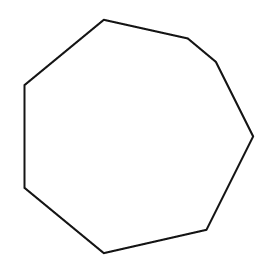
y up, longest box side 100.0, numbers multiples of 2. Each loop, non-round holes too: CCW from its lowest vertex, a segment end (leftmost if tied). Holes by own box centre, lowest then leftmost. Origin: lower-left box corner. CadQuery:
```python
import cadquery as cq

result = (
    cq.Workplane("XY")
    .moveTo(34.0, 0.0)
    .lineTo(78.0, 10.0)
    .lineTo(98.0, 50.0)
    .lineTo(82.0, 82.0)
    .lineTo(70.0, 92.0)
    .lineTo(34.0, 100.0)
    .lineTo(0.0, 72.0)
    .lineTo(0.0, 28.0)
    .close()
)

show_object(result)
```